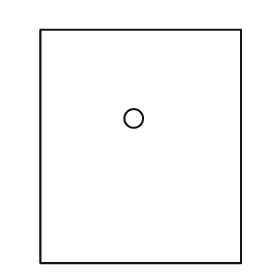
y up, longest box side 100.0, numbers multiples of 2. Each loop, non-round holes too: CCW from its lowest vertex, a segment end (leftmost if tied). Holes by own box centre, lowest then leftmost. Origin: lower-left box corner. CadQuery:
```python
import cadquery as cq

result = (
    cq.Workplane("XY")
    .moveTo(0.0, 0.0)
    .lineTo(86.0, 0.0)
    .lineTo(86.0, 100.0)
    .lineTo(0.0, 100.0)
    .close()
    .moveTo(40.0, 62.0)
    .circle(4.0)
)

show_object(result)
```